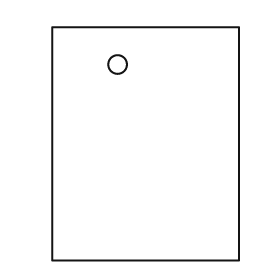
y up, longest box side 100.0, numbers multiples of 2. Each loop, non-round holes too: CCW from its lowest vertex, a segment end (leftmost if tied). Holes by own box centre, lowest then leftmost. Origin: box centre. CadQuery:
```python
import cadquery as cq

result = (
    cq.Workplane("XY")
    .moveTo(-40.0, -50.0)
    .lineTo(40.0, -50.0)
    .lineTo(40.0, 50.0)
    .lineTo(-40.0, 50.0)
    .close()
    .moveTo(-12.0, 34.0)
    .circle(4.0)
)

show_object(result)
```